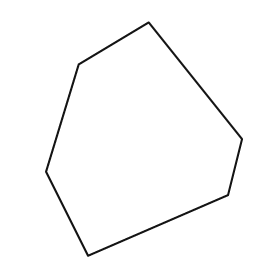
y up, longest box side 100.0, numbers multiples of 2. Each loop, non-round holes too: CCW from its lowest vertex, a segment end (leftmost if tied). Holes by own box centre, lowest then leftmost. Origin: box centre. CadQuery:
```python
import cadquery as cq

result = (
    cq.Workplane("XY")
    .moveTo(-24.0, -50.0)
    .lineTo(36.0, -24.0)
    .lineTo(42.0, 0.0)
    .lineTo(2.0, 50.0)
    .lineTo(-28.0, 32.0)
    .lineTo(-42.0, -14.0)
    .close()
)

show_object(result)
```